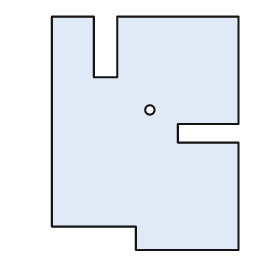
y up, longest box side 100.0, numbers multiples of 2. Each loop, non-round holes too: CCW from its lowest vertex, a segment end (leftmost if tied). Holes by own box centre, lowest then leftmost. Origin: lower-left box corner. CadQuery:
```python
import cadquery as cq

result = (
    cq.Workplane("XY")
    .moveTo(36.0, 0.0)
    .lineTo(80.0, 0.0)
    .lineTo(80.0, 46.0)
    .lineTo(54.0, 46.0)
    .lineTo(54.0, 54.0)
    .lineTo(80.0, 54.0)
    .lineTo(80.0, 100.0)
    .lineTo(28.0, 100.0)
    .lineTo(28.0, 74.0)
    .lineTo(18.0, 74.0)
    .lineTo(18.0, 100.0)
    .lineTo(0.0, 100.0)
    .lineTo(0.0, 10.0)
    .lineTo(36.0, 10.0)
    .close()
    .moveTo(42.0, 60.0)
    .circle(2.0)
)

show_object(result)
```